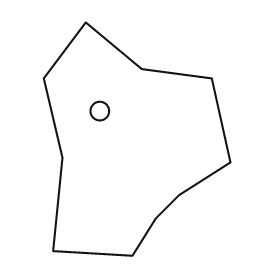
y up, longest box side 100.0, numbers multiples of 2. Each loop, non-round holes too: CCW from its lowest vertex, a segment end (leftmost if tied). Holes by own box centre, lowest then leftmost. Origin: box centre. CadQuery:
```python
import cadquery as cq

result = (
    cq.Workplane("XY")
    .moveTo(-2.0, -50.0)
    .lineTo(8.0, -34.0)
    .lineTo(18.0, -24.0)
    .lineTo(40.0, -10.0)
    .lineTo(32.0, 26.0)
    .lineTo(2.0, 30.0)
    .lineTo(-22.0, 50.0)
    .lineTo(-40.0, 26.0)
    .lineTo(-32.0, -8.0)
    .lineTo(-36.0, -48.0)
    .close()
    .moveTo(-16.0, 12.0)
    .circle(4.0)
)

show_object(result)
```